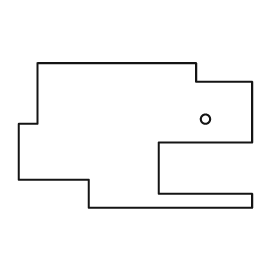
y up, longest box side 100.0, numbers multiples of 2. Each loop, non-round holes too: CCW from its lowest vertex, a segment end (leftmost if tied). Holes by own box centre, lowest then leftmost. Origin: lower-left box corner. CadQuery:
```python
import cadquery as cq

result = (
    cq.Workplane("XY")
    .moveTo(30.0, 0.0)
    .lineTo(100.0, 0.0)
    .lineTo(100.0, 6.0)
    .lineTo(60.0, 6.0)
    .lineTo(60.0, 28.0)
    .lineTo(100.0, 28.0)
    .lineTo(100.0, 54.0)
    .lineTo(76.0, 54.0)
    .lineTo(76.0, 62.0)
    .lineTo(8.0, 62.0)
    .lineTo(8.0, 36.0)
    .lineTo(0.0, 36.0)
    .lineTo(0.0, 12.0)
    .lineTo(30.0, 12.0)
    .close()
    .moveTo(80.0, 38.0)
    .circle(2.0)
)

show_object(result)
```